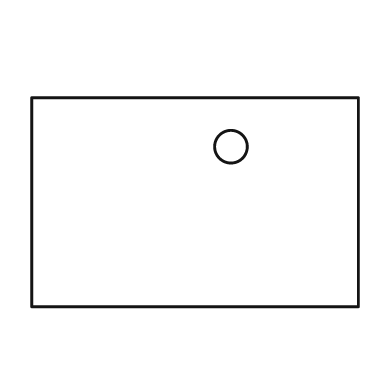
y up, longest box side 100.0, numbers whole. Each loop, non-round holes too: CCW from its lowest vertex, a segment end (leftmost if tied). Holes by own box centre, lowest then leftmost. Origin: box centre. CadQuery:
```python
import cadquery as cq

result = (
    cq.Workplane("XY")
    .moveTo(-50.0, -32.0)
    .lineTo(50.0, -32.0)
    .lineTo(50.0, 32.0)
    .lineTo(-50.0, 32.0)
    .close()
    .moveTo(11.0, 17.0)
    .circle(5.0)
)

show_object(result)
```